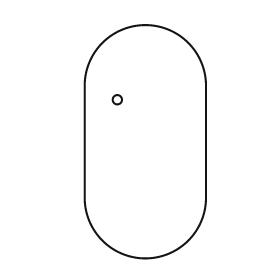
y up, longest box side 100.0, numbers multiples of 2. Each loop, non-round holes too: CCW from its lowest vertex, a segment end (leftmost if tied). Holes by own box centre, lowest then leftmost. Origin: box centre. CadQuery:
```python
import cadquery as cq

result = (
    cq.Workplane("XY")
    .moveTo(-26.0, -24.0)
    .threePointArc((0.0, -50.0), (26.0, -24.0))
    .lineTo(26.0, 24.0)
    .threePointArc((0.0, 50.0), (-26.0, 24.0))
    .close()
    .moveTo(-12.0, 18.0)
    .circle(2.0)
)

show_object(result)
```